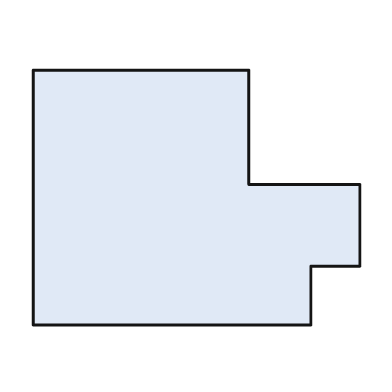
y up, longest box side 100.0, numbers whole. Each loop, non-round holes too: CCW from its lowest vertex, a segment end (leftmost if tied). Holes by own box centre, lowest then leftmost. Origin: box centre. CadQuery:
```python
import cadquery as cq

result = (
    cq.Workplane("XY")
    .moveTo(-50.0, -39.0)
    .lineTo(35.0, -39.0)
    .lineTo(35.0, -21.0)
    .lineTo(50.0, -21.0)
    .lineTo(50.0, 4.0)
    .lineTo(16.0, 4.0)
    .lineTo(16.0, 39.0)
    .lineTo(-50.0, 39.0)
    .close()
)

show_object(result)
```